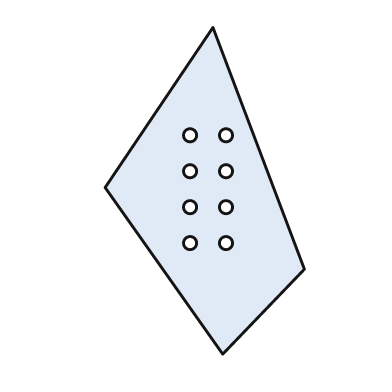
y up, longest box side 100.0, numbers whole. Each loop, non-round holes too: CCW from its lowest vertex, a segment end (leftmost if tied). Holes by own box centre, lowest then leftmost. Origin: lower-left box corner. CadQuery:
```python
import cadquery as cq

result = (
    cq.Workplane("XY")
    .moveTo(36.0, 0.0)
    .lineTo(61.0, 26.0)
    .lineTo(33.0, 100.0)
    .lineTo(0.0, 51.0)
    .close()
    .moveTo(26.0, 34.0)
    .circle(2.0)
    .moveTo(37.0, 34.0)
    .circle(2.0)
    .moveTo(26.0, 45.0)
    .circle(2.0)
    .moveTo(37.0, 45.0)
    .circle(2.0)
    .moveTo(26.0, 56.0)
    .circle(2.0)
    .moveTo(37.0, 56.0)
    .circle(2.0)
    .moveTo(26.0, 67.0)
    .circle(2.0)
    .moveTo(37.0, 67.0)
    .circle(2.0)
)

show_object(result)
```